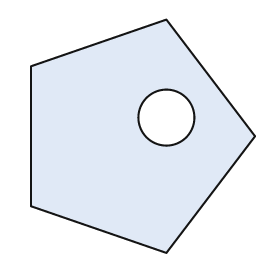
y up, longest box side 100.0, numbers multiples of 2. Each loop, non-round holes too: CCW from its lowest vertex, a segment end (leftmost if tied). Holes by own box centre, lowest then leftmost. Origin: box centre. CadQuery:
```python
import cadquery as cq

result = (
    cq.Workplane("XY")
    .moveTo(10.0, -50.0)
    .lineTo(48.0, 0.0)
    .lineTo(10.0, 50.0)
    .lineTo(-48.0, 30.0)
    .lineTo(-48.0, -30.0)
    .close()
    .moveTo(10.0, 8.0)
    .circle(12.0)
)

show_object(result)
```